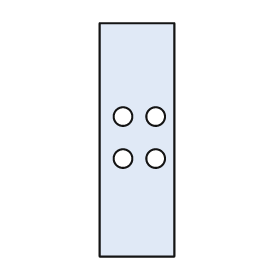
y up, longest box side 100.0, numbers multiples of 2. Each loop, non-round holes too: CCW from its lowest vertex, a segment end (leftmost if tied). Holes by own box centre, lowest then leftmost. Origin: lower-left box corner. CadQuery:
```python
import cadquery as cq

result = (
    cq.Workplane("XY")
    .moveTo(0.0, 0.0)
    .lineTo(32.0, 0.0)
    .lineTo(32.0, 100.0)
    .lineTo(0.0, 100.0)
    .close()
    .moveTo(10.0, 42.0)
    .circle(4.0)
    .moveTo(24.0, 42.0)
    .circle(4.0)
    .moveTo(10.0, 60.0)
    .circle(4.0)
    .moveTo(24.0, 60.0)
    .circle(4.0)
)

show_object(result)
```